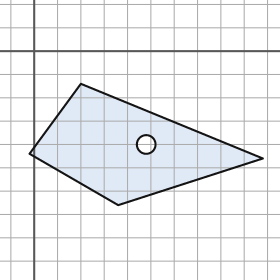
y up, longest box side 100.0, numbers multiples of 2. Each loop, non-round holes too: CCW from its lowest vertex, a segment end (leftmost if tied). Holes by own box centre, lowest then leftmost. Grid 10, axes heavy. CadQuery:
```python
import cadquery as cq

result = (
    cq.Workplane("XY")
    .moveTo(36.0, -66.0)
    .lineTo(98.0, -46.0)
    .lineTo(20.0, -14.0)
    .lineTo(-2.0, -44.0)
    .close()
    .moveTo(48.0, -40.0)
    .circle(4.0)
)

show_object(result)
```